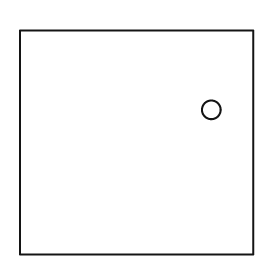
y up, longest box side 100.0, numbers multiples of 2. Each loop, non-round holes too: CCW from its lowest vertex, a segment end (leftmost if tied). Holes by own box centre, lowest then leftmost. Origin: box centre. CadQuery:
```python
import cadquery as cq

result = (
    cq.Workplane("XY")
    .moveTo(-50.0, -48.0)
    .lineTo(50.0, -48.0)
    .lineTo(50.0, 48.0)
    .lineTo(-50.0, 48.0)
    .close()
    .moveTo(32.0, 14.0)
    .circle(4.0)
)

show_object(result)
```